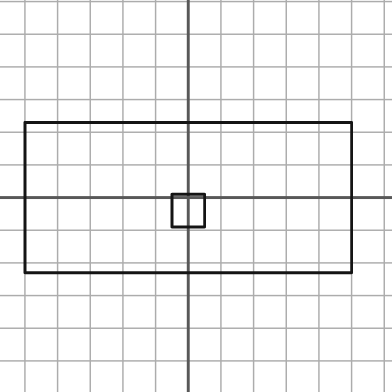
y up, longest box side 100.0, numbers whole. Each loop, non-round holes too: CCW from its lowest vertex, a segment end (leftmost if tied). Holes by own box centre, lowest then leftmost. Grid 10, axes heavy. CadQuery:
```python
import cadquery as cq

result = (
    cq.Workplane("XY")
    .moveTo(-50.0, -23.0)
    .lineTo(50.0, -23.0)
    .lineTo(50.0, 23.0)
    .lineTo(-50.0, 23.0)
    .close()
    .moveTo(-5.0, -9.0)
    .lineTo(5.0, -9.0)
    .lineTo(5.0, 1.0)
    .lineTo(-5.0, 1.0)
    .close()
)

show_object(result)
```